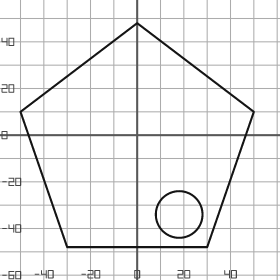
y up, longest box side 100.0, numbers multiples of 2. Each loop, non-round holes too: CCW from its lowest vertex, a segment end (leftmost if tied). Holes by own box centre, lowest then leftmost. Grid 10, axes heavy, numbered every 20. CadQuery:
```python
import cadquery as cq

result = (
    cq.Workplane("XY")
    .moveTo(-30.0, -48.0)
    .lineTo(30.0, -48.0)
    .lineTo(50.0, 10.0)
    .lineTo(0.0, 48.0)
    .lineTo(-50.0, 10.0)
    .close()
    .moveTo(18.0, -34.0)
    .circle(10.0)
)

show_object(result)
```